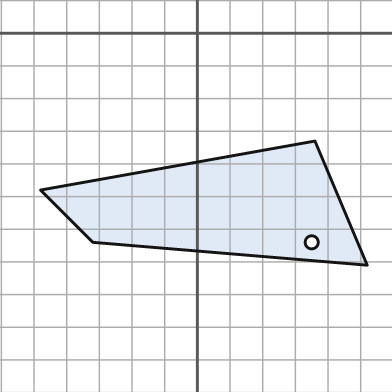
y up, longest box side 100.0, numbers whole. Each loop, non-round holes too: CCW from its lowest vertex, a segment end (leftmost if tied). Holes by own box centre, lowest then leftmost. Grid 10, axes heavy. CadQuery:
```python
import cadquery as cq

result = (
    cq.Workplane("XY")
    .moveTo(52.0, -71.0)
    .lineTo(36.0, -33.0)
    .lineTo(-48.0, -48.0)
    .lineTo(-32.0, -64.0)
    .close()
    .moveTo(35.0, -64.0)
    .circle(2.0)
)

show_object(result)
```